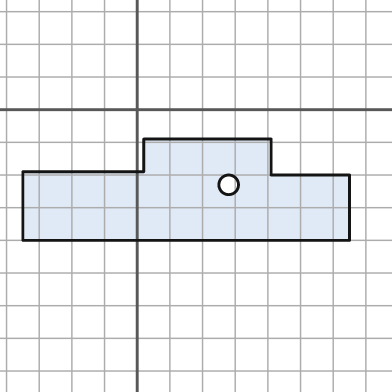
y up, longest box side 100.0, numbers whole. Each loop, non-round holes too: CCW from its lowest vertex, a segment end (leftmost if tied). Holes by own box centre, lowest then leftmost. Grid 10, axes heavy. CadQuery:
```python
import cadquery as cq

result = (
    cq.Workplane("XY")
    .moveTo(-35.0, -40.0)
    .lineTo(65.0, -40.0)
    .lineTo(65.0, -20.0)
    .lineTo(41.0, -20.0)
    .lineTo(41.0, -9.0)
    .lineTo(2.0, -9.0)
    .lineTo(2.0, -19.0)
    .lineTo(-35.0, -19.0)
    .close()
    .moveTo(28.0, -23.0)
    .circle(3.0)
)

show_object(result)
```